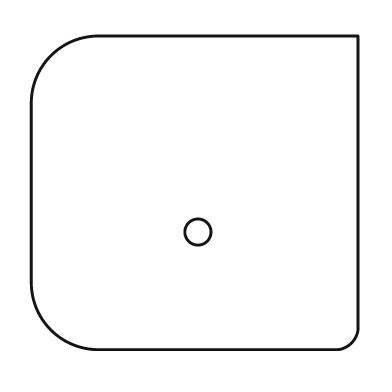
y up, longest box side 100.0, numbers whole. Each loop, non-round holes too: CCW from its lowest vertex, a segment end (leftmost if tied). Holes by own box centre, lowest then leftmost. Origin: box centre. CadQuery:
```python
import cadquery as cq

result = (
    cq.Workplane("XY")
    .moveTo(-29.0, -48.0)
    .lineTo(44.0, -48.0)
    .threePointArc((48.0, -46.0), (50.0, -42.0))
    .lineTo(50.0, 48.0)
    .lineTo(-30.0, 48.0)
    .threePointArc((-44.0, 42.0), (-50.0, 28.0))
    .lineTo(-50.0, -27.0)
    .threePointArc((-44.0, -42.0), (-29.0, -48.0))
    .close()
    .moveTo(1.0, -12.0)
    .circle(4.0)
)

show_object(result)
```